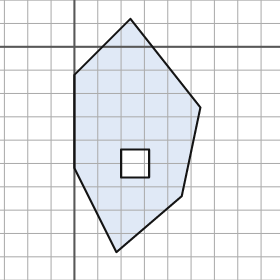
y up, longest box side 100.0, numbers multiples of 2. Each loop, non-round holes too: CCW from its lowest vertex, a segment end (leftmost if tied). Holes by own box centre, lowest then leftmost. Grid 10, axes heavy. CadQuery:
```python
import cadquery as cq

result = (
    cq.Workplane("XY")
    .moveTo(18.0, -88.0)
    .lineTo(46.0, -64.0)
    .lineTo(54.0, -26.0)
    .lineTo(24.0, 12.0)
    .lineTo(0.0, -12.0)
    .lineTo(0.0, -52.0)
    .close()
    .moveTo(20.0, -56.0)
    .lineTo(32.0, -56.0)
    .lineTo(32.0, -44.0)
    .lineTo(20.0, -44.0)
    .close()
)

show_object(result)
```